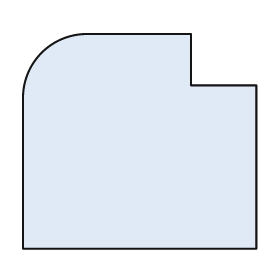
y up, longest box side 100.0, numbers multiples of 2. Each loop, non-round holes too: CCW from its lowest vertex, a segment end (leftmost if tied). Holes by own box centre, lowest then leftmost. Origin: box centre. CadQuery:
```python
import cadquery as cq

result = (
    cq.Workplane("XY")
    .moveTo(-50.0, -46.0)
    .lineTo(50.0, -46.0)
    .lineTo(50.0, 24.0)
    .lineTo(22.0, 24.0)
    .lineTo(22.0, 46.0)
    .lineTo(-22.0, 46.0)
    .threePointArc((-42.0, 38.0), (-50.0, 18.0))
    .close()
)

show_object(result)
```